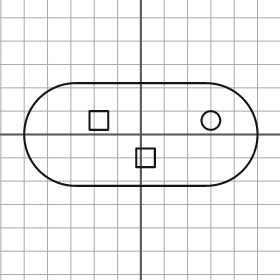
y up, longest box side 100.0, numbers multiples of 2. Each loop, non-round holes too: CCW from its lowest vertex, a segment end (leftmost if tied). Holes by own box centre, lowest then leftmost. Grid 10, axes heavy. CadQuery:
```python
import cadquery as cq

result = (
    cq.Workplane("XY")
    .moveTo(-28.0, -22.0)
    .lineTo(28.0, -22.0)
    .threePointArc((50.0, 0.0), (28.0, 22.0))
    .lineTo(-28.0, 22.0)
    .threePointArc((-50.0, 0.0), (-28.0, -22.0))
    .close()
    .moveTo(-2.0, -14.0)
    .lineTo(6.0, -14.0)
    .lineTo(6.0, -6.0)
    .lineTo(-2.0, -6.0)
    .close()
    .moveTo(-22.0, 2.0)
    .lineTo(-14.0, 2.0)
    .lineTo(-14.0, 10.0)
    .lineTo(-22.0, 10.0)
    .close()
    .moveTo(30.0, 6.0)
    .circle(4.0)
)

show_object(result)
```